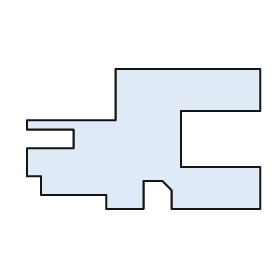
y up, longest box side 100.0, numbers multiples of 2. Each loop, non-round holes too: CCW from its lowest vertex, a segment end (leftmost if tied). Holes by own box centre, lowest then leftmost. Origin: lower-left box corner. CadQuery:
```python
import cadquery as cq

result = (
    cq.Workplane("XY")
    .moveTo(34.0, 0.0)
    .lineTo(50.0, 0.0)
    .lineTo(50.0, 12.0)
    .lineTo(58.0, 12.0)
    .lineTo(62.0, 8.0)
    .lineTo(62.0, 0.0)
    .lineTo(100.0, 0.0)
    .lineTo(100.0, 18.0)
    .lineTo(66.0, 18.0)
    .lineTo(66.0, 42.0)
    .lineTo(100.0, 42.0)
    .lineTo(100.0, 60.0)
    .lineTo(38.0, 60.0)
    .lineTo(38.0, 38.0)
    .lineTo(0.0, 38.0)
    .lineTo(0.0, 34.0)
    .lineTo(20.0, 34.0)
    .lineTo(20.0, 26.0)
    .lineTo(0.0, 26.0)
    .lineTo(0.0, 14.0)
    .lineTo(6.0, 14.0)
    .lineTo(6.0, 6.0)
    .lineTo(34.0, 6.0)
    .close()
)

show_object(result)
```